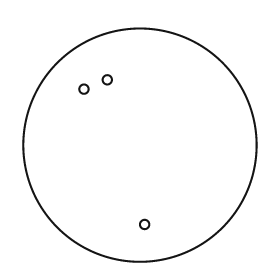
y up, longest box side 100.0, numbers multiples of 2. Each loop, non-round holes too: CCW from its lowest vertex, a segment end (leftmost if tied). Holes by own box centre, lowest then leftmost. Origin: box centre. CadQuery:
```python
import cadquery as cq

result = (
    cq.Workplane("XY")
    .moveTo(0.0, 0.0)
    .circle(50.0)
    .moveTo(2.0, -34.0)
    .circle(2.0)
    .moveTo(-24.0, 24.0)
    .circle(2.0)
    .moveTo(-14.0, 28.0)
    .circle(2.0)
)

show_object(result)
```